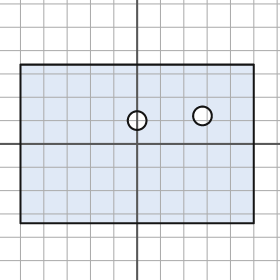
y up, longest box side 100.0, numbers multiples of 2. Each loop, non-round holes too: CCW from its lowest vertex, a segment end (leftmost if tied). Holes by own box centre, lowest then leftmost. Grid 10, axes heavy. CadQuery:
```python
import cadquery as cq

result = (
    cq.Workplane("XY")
    .moveTo(-50.0, -34.0)
    .lineTo(50.0, -34.0)
    .lineTo(50.0, 34.0)
    .lineTo(-50.0, 34.0)
    .close()
    .moveTo(0.0, 10.0)
    .circle(4.0)
    .moveTo(28.0, 12.0)
    .circle(4.0)
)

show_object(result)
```